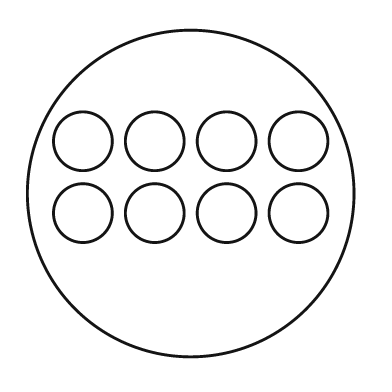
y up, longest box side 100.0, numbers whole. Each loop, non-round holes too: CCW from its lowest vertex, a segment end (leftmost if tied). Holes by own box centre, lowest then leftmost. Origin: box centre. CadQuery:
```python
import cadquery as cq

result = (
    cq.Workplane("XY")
    .moveTo(0.0, 0.0)
    .circle(50.0)
    .moveTo(-33.0, -6.0)
    .circle(9.0)
    .moveTo(-11.0, -6.0)
    .circle(9.0)
    .moveTo(11.0, -6.0)
    .circle(9.0)
    .moveTo(33.0, -6.0)
    .circle(9.0)
    .moveTo(-33.0, 16.0)
    .circle(9.0)
    .moveTo(-11.0, 16.0)
    .circle(9.0)
    .moveTo(11.0, 16.0)
    .circle(9.0)
    .moveTo(33.0, 16.0)
    .circle(9.0)
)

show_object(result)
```